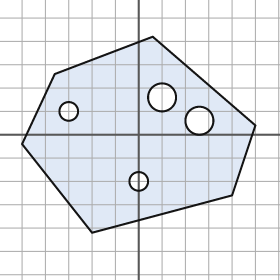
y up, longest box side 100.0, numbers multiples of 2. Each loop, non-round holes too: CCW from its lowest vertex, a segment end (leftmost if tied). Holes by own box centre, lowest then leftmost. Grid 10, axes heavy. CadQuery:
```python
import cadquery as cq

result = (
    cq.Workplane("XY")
    .moveTo(-20.0, -42.0)
    .lineTo(40.0, -26.0)
    .lineTo(50.0, 4.0)
    .lineTo(6.0, 42.0)
    .lineTo(-36.0, 26.0)
    .lineTo(-50.0, -4.0)
    .close()
    .moveTo(0.0, -20.0)
    .circle(4.0)
    .moveTo(26.0, 6.0)
    .circle(6.0)
    .moveTo(-30.0, 10.0)
    .circle(4.0)
    .moveTo(10.0, 16.0)
    .circle(6.0)
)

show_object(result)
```